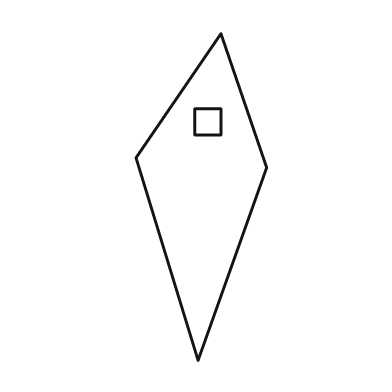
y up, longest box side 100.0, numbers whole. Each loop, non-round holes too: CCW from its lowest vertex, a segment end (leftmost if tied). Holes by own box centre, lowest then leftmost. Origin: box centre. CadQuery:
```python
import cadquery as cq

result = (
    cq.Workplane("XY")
    .moveTo(-1.0, -50.0)
    .lineTo(20.0, 9.0)
    .lineTo(6.0, 50.0)
    .lineTo(-20.0, 12.0)
    .close()
    .moveTo(-2.0, 19.0)
    .lineTo(6.0, 19.0)
    .lineTo(6.0, 27.0)
    .lineTo(-2.0, 27.0)
    .close()
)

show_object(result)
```